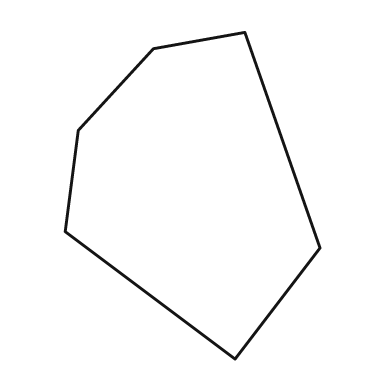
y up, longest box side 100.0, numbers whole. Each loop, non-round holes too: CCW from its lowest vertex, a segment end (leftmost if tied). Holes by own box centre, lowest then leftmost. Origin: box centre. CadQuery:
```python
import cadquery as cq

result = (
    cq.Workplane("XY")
    .moveTo(13.0, -50.0)
    .lineTo(39.0, -16.0)
    .lineTo(16.0, 50.0)
    .lineTo(-12.0, 45.0)
    .lineTo(-35.0, 20.0)
    .lineTo(-39.0, -11.0)
    .close()
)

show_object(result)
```